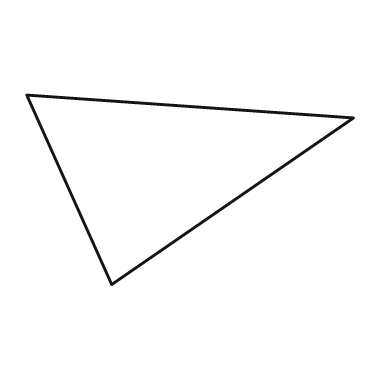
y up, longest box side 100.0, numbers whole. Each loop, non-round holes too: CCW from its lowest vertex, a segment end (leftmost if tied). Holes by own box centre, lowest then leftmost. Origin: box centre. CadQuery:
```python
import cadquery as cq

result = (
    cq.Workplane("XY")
    .moveTo(-24.0, -29.0)
    .lineTo(50.0, 22.0)
    .lineTo(-50.0, 29.0)
    .close()
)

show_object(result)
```